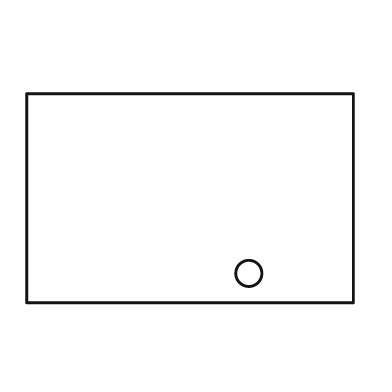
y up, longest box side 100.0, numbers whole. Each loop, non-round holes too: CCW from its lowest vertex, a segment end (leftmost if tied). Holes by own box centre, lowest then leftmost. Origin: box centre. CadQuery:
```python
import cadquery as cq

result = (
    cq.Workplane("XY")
    .moveTo(-50.0, -32.0)
    .lineTo(50.0, -32.0)
    .lineTo(50.0, 32.0)
    .lineTo(-50.0, 32.0)
    .close()
    .moveTo(18.0, -23.0)
    .circle(4.0)
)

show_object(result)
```